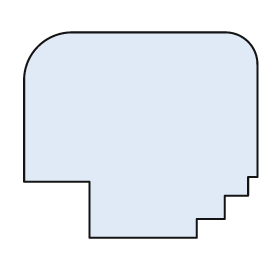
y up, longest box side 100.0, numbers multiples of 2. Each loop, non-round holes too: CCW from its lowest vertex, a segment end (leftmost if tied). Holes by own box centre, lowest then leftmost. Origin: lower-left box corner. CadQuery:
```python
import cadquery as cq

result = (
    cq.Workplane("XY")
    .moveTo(28.0, 0.0)
    .lineTo(74.0, 0.0)
    .lineTo(74.0, 8.0)
    .lineTo(86.0, 8.0)
    .lineTo(86.0, 18.0)
    .lineTo(96.0, 18.0)
    .lineTo(96.0, 26.0)
    .lineTo(100.0, 26.0)
    .lineTo(100.0, 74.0)
    .threePointArc((96.0, 84.0), (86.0, 88.0))
    .lineTo(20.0, 88.0)
    .threePointArc((6.0, 82.0), (0.0, 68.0))
    .lineTo(0.0, 24.0)
    .lineTo(28.0, 24.0)
    .close()
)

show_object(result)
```